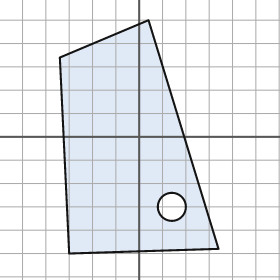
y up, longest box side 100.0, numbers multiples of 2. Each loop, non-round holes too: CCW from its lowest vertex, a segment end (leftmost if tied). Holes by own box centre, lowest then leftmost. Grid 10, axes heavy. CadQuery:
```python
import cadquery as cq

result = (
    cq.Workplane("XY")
    .moveTo(-30.0, -50.0)
    .lineTo(34.0, -48.0)
    .lineTo(4.0, 50.0)
    .lineTo(-34.0, 34.0)
    .close()
    .moveTo(14.0, -30.0)
    .circle(6.0)
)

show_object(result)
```